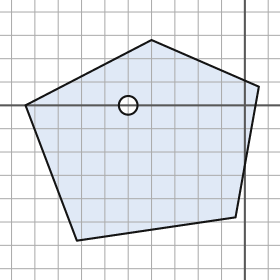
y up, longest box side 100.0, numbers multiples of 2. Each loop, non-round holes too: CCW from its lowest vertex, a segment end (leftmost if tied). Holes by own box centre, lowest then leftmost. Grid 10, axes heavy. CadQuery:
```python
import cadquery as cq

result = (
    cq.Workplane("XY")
    .moveTo(-72.0, -58.0)
    .lineTo(-4.0, -48.0)
    .lineTo(6.0, 8.0)
    .lineTo(-40.0, 28.0)
    .lineTo(-94.0, 0.0)
    .close()
    .moveTo(-50.0, 0.0)
    .circle(4.0)
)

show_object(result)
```